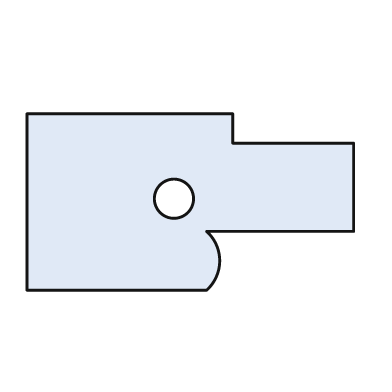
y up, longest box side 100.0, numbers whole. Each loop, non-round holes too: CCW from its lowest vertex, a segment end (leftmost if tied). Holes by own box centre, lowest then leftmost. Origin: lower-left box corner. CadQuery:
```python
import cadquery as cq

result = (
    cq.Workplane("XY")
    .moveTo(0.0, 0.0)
    .lineTo(55.0, 0.0)
    .threePointArc((59.0, 9.0), (55.0, 18.0))
    .lineTo(100.0, 18.0)
    .lineTo(100.0, 45.0)
    .lineTo(63.0, 45.0)
    .lineTo(63.0, 54.0)
    .lineTo(0.0, 54.0)
    .close()
    .moveTo(45.0, 28.0)
    .circle(6.0)
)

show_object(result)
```